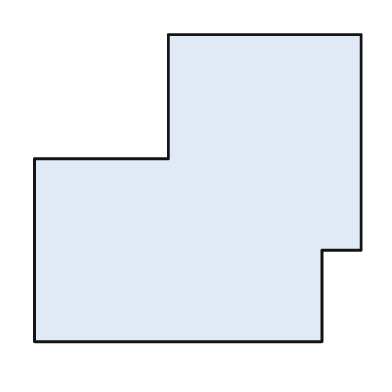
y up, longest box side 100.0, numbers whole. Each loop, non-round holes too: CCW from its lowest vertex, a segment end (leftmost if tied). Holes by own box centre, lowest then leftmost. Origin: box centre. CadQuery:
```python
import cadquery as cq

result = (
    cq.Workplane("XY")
    .moveTo(-50.0, -47.0)
    .lineTo(38.0, -47.0)
    .lineTo(38.0, -19.0)
    .lineTo(50.0, -19.0)
    .lineTo(50.0, 47.0)
    .lineTo(-9.0, 47.0)
    .lineTo(-9.0, 9.0)
    .lineTo(-50.0, 9.0)
    .close()
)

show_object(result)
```